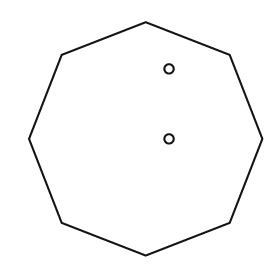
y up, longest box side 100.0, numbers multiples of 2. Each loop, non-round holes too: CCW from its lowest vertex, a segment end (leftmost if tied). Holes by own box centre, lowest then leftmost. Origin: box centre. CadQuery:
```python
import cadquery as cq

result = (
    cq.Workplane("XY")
    .moveTo(0.0, -50.0)
    .lineTo(36.0, -36.0)
    .lineTo(50.0, 0.0)
    .lineTo(36.0, 36.0)
    .lineTo(0.0, 50.0)
    .lineTo(-36.0, 36.0)
    .lineTo(-50.0, 0.0)
    .lineTo(-36.0, -36.0)
    .close()
    .moveTo(10.0, 0.0)
    .circle(2.0)
    .moveTo(10.0, 30.0)
    .circle(2.0)
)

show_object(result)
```